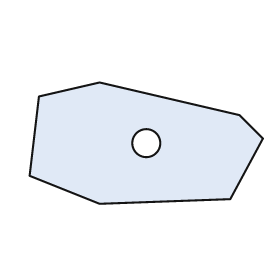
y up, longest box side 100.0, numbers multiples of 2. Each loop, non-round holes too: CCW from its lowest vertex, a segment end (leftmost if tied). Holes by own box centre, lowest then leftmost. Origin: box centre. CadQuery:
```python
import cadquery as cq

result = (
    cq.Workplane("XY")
    .moveTo(-20.0, -26.0)
    .lineTo(36.0, -24.0)
    .lineTo(50.0, 2.0)
    .lineTo(40.0, 12.0)
    .lineTo(-20.0, 26.0)
    .lineTo(-46.0, 20.0)
    .lineTo(-50.0, -14.0)
    .close()
    .moveTo(0.0, 0.0)
    .circle(6.0)
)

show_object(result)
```